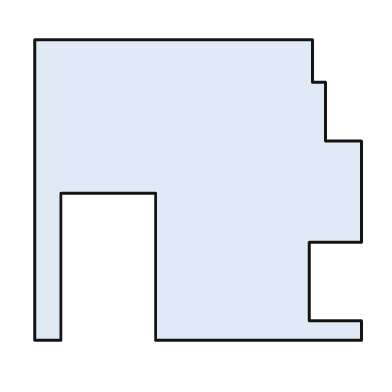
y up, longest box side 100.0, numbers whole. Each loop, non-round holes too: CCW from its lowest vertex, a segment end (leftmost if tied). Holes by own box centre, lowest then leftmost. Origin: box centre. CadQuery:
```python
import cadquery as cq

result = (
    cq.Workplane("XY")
    .moveTo(-50.0, -46.0)
    .lineTo(-42.0, -46.0)
    .lineTo(-42.0, -1.0)
    .lineTo(-13.0, -1.0)
    .lineTo(-13.0, -46.0)
    .lineTo(50.0, -46.0)
    .lineTo(50.0, -40.0)
    .lineTo(34.0, -40.0)
    .lineTo(34.0, -16.0)
    .lineTo(50.0, -16.0)
    .lineTo(50.0, 15.0)
    .lineTo(39.0, 15.0)
    .lineTo(39.0, 33.0)
    .lineTo(35.0, 33.0)
    .lineTo(35.0, 46.0)
    .lineTo(-50.0, 46.0)
    .close()
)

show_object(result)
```